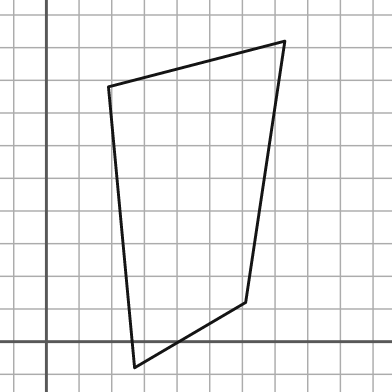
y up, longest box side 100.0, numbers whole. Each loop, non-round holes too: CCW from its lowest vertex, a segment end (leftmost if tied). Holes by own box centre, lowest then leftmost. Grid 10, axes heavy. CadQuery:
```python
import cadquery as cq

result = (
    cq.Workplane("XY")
    .moveTo(27.0, -8.0)
    .lineTo(61.0, 12.0)
    .lineTo(73.0, 92.0)
    .lineTo(19.0, 78.0)
    .close()
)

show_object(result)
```